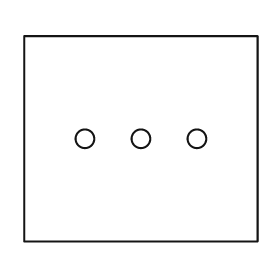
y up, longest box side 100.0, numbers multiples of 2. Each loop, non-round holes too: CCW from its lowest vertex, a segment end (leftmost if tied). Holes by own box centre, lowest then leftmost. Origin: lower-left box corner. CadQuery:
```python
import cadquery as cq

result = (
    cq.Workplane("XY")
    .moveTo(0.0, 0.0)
    .lineTo(100.0, 0.0)
    .lineTo(100.0, 88.0)
    .lineTo(0.0, 88.0)
    .close()
    .moveTo(26.0, 44.0)
    .circle(4.0)
    .moveTo(50.0, 44.0)
    .circle(4.0)
    .moveTo(74.0, 44.0)
    .circle(4.0)
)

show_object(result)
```